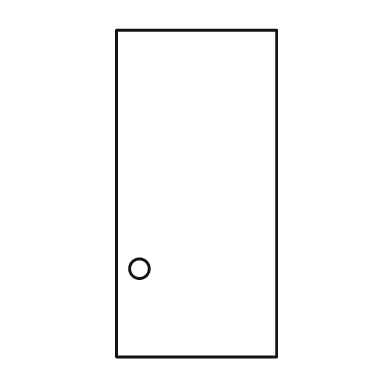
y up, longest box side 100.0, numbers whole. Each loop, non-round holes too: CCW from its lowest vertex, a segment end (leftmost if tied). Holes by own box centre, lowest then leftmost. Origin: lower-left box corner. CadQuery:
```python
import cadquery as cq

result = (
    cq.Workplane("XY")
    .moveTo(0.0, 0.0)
    .lineTo(49.0, 0.0)
    .lineTo(49.0, 100.0)
    .lineTo(0.0, 100.0)
    .close()
    .moveTo(7.0, 27.0)
    .circle(3.0)
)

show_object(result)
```